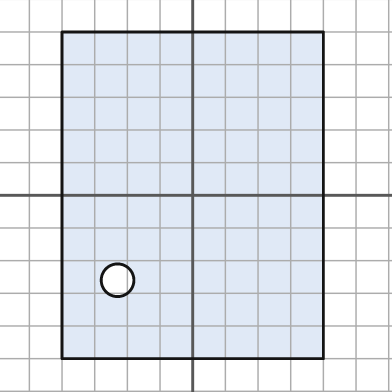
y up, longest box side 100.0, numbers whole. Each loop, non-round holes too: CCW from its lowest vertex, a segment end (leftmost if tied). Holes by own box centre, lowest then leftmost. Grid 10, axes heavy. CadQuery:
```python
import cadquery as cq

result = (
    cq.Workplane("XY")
    .moveTo(-40.0, -50.0)
    .lineTo(40.0, -50.0)
    .lineTo(40.0, 50.0)
    .lineTo(-40.0, 50.0)
    .close()
    .moveTo(-23.0, -26.0)
    .circle(5.0)
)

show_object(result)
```